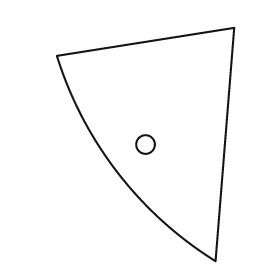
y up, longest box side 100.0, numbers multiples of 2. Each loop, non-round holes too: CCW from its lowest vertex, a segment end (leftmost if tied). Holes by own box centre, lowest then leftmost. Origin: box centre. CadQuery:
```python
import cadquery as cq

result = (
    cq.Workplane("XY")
    .moveTo(30.0, -50.0)
    .lineTo(38.0, 50.0)
    .lineTo(-38.0, 38.0)
    .threePointArc((-12.0, -12.0), (30.0, -50.0))
    .close()
    .moveTo(0.0, 0.0)
    .circle(4.0)
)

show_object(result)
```